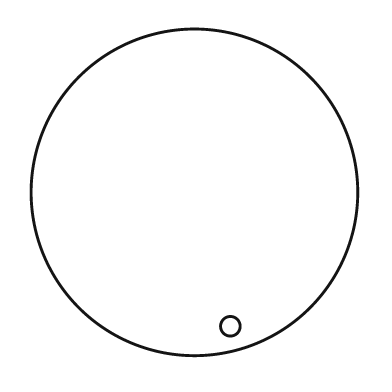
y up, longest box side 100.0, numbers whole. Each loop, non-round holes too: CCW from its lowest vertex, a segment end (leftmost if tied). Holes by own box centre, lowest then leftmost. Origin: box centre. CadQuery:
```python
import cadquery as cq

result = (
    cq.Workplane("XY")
    .moveTo(0.0, 0.0)
    .circle(50.0)
    .moveTo(11.0, -41.0)
    .circle(3.0)
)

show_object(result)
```